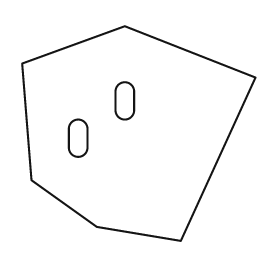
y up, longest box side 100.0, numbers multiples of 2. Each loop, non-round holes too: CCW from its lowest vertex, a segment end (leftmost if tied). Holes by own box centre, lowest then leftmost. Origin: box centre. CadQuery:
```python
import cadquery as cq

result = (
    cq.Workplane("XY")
    .moveTo(18.0, -46.0)
    .lineTo(50.0, 24.0)
    .lineTo(-6.0, 46.0)
    .lineTo(-50.0, 30.0)
    .lineTo(-46.0, -20.0)
    .lineTo(-18.0, -40.0)
    .close()
    .moveTo(-30.0, -6.0)
    .threePointArc((-26.0, -10.0), (-22.0, -6.0))
    .lineTo(-22.0, 2.0)
    .threePointArc((-26.0, 6.0), (-30.0, 2.0))
    .close()
    .moveTo(-10.0, 10.0)
    .threePointArc((-6.0, 6.0), (-2.0, 10.0))
    .lineTo(-2.0, 18.0)
    .threePointArc((-6.0, 22.0), (-10.0, 18.0))
    .close()
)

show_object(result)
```